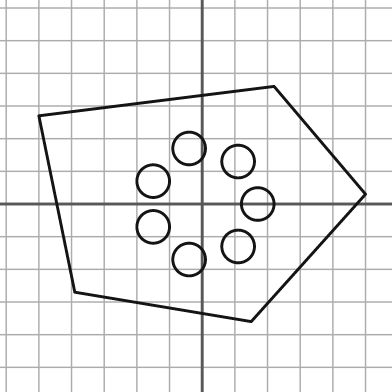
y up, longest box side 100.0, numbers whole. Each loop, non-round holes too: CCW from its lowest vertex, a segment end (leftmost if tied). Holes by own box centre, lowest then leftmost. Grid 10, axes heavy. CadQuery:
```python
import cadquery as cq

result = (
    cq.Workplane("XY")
    .moveTo(15.0, -36.0)
    .lineTo(50.0, 3.0)
    .lineTo(22.0, 36.0)
    .lineTo(-50.0, 27.0)
    .lineTo(-39.0, -27.0)
    .close()
    .moveTo(-4.0, -17.0)
    .circle(5.0)
    .moveTo(11.0, -13.0)
    .circle(5.0)
    .moveTo(-15.0, -7.0)
    .circle(5.0)
    .moveTo(17.0, 0.0)
    .circle(5.0)
    .moveTo(-15.0, 7.0)
    .circle(5.0)
    .moveTo(11.0, 13.0)
    .circle(5.0)
    .moveTo(-4.0, 17.0)
    .circle(5.0)
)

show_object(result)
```